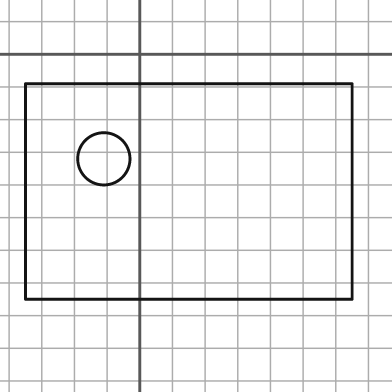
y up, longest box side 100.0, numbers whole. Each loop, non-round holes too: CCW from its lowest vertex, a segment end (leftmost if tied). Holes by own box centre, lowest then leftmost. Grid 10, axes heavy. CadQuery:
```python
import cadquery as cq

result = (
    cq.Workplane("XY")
    .moveTo(-35.0, -75.0)
    .lineTo(65.0, -75.0)
    .lineTo(65.0, -9.0)
    .lineTo(-35.0, -9.0)
    .close()
    .moveTo(-11.0, -32.0)
    .circle(8.0)
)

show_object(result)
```